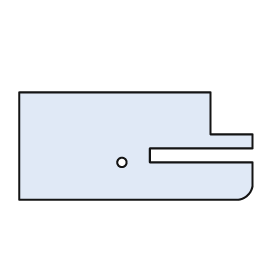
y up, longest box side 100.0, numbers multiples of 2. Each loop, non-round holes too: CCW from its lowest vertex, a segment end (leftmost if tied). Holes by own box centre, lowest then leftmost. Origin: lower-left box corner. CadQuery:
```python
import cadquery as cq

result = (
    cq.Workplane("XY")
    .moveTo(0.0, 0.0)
    .lineTo(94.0, 0.0)
    .threePointArc((98.0, 2.0), (100.0, 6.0))
    .lineTo(100.0, 16.0)
    .lineTo(56.0, 16.0)
    .lineTo(56.0, 22.0)
    .lineTo(100.0, 22.0)
    .lineTo(100.0, 28.0)
    .lineTo(82.0, 28.0)
    .lineTo(82.0, 46.0)
    .lineTo(0.0, 46.0)
    .close()
    .moveTo(44.0, 16.0)
    .circle(2.0)
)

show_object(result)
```